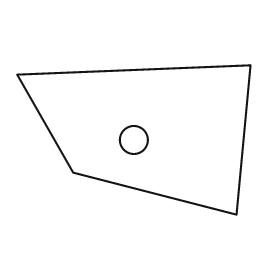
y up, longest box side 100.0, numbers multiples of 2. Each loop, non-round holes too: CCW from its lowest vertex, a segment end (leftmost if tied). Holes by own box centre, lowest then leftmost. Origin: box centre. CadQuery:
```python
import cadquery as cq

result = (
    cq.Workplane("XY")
    .moveTo(44.0, -32.0)
    .lineTo(50.0, 32.0)
    .lineTo(-50.0, 28.0)
    .lineTo(-26.0, -14.0)
    .close()
    .moveTo(0.0, 0.0)
    .circle(6.0)
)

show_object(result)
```